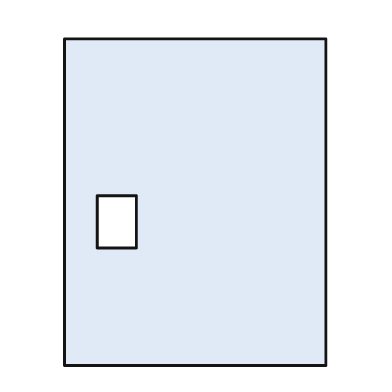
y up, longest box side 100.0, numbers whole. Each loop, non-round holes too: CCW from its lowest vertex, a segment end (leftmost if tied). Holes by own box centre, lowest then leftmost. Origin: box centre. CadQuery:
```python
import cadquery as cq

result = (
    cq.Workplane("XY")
    .moveTo(-40.0, -50.0)
    .lineTo(40.0, -50.0)
    .lineTo(40.0, 50.0)
    .lineTo(-40.0, 50.0)
    .close()
    .moveTo(-30.0, -14.0)
    .lineTo(-18.0, -14.0)
    .lineTo(-18.0, 2.0)
    .lineTo(-30.0, 2.0)
    .close()
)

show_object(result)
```